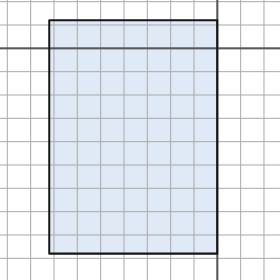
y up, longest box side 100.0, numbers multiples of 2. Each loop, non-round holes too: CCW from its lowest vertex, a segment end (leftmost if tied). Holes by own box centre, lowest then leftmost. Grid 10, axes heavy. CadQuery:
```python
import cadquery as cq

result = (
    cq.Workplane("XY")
    .moveTo(-72.0, -88.0)
    .lineTo(0.0, -88.0)
    .lineTo(0.0, 12.0)
    .lineTo(-72.0, 12.0)
    .close()
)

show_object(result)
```